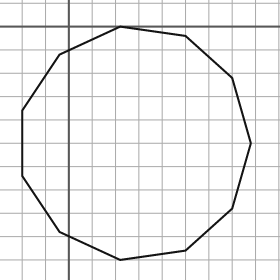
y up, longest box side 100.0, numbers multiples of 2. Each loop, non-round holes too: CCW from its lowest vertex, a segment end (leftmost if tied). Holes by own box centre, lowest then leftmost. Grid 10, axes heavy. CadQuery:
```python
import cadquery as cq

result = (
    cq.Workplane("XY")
    .moveTo(22.0, -100.0)
    .lineTo(50.0, -96.0)
    .lineTo(70.0, -78.0)
    .lineTo(78.0, -50.0)
    .lineTo(70.0, -22.0)
    .lineTo(50.0, -4.0)
    .lineTo(22.0, 0.0)
    .lineTo(-4.0, -12.0)
    .lineTo(-20.0, -36.0)
    .lineTo(-20.0, -64.0)
    .lineTo(-4.0, -88.0)
    .close()
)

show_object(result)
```